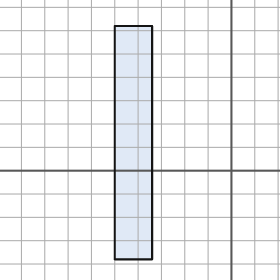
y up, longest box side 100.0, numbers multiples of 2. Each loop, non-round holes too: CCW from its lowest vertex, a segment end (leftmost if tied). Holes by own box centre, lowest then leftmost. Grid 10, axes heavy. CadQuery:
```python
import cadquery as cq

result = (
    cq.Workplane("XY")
    .moveTo(-50.0, -38.0)
    .lineTo(-34.0, -38.0)
    .lineTo(-34.0, 62.0)
    .lineTo(-50.0, 62.0)
    .close()
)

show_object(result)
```